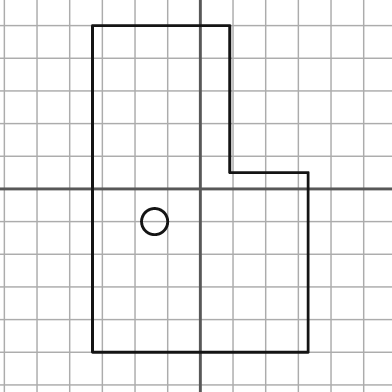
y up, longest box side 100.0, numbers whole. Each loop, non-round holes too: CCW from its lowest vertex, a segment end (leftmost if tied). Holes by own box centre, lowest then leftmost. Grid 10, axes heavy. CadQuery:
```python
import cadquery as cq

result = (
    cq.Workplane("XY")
    .moveTo(-33.0, -50.0)
    .lineTo(33.0, -50.0)
    .lineTo(33.0, 5.0)
    .lineTo(9.0, 5.0)
    .lineTo(9.0, 50.0)
    .lineTo(-33.0, 50.0)
    .close()
    .moveTo(-14.0, -10.0)
    .circle(4.0)
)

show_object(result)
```